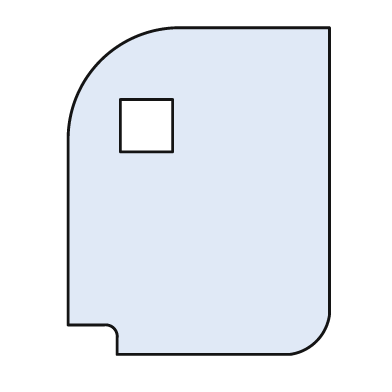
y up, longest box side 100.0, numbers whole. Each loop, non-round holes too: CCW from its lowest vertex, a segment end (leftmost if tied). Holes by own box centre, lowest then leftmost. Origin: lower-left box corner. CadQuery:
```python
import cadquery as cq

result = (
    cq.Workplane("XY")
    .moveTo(15.0, 0.0)
    .lineTo(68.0, 0.0)
    .threePointArc((76.0, 4.0), (80.0, 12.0))
    .lineTo(80.0, 100.0)
    .lineTo(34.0, 100.0)
    .threePointArc((10.0, 90.0), (0.0, 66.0))
    .lineTo(0.0, 9.0)
    .lineTo(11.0, 9.0)
    .threePointArc((14.0, 8.0), (15.0, 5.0))
    .close()
    .moveTo(16.0, 62.0)
    .lineTo(32.0, 62.0)
    .lineTo(32.0, 78.0)
    .lineTo(16.0, 78.0)
    .close()
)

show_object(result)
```